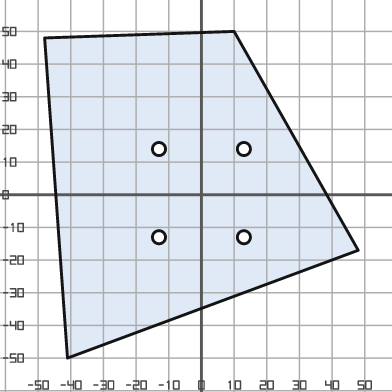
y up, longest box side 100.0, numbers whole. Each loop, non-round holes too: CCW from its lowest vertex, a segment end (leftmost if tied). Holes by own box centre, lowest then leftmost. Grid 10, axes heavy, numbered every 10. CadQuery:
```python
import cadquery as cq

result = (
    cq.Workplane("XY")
    .moveTo(-41.0, -50.0)
    .lineTo(48.0, -17.0)
    .lineTo(10.0, 50.0)
    .lineTo(-48.0, 48.0)
    .close()
    .moveTo(-13.0, -13.0)
    .circle(2.0)
    .moveTo(13.0, -13.0)
    .circle(2.0)
    .moveTo(-13.0, 14.0)
    .circle(2.0)
    .moveTo(13.0, 14.0)
    .circle(2.0)
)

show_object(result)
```